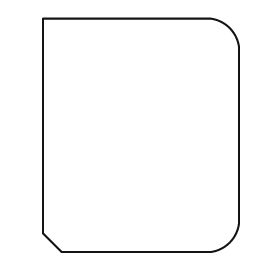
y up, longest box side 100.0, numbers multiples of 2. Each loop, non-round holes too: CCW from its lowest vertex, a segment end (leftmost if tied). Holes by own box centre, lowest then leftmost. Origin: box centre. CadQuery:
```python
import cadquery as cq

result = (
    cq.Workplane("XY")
    .moveTo(-34.0, -50.0)
    .lineTo(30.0, -50.0)
    .threePointArc((38.0, -46.0), (42.0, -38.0))
    .lineTo(42.0, 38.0)
    .threePointArc((38.0, 46.0), (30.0, 50.0))
    .lineTo(-42.0, 50.0)
    .lineTo(-42.0, -42.0)
    .close()
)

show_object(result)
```